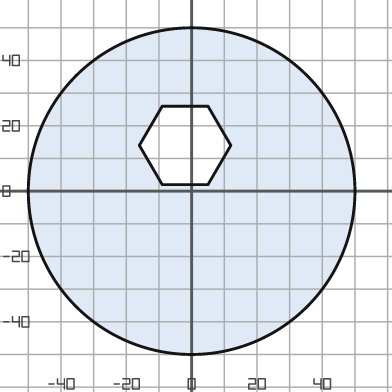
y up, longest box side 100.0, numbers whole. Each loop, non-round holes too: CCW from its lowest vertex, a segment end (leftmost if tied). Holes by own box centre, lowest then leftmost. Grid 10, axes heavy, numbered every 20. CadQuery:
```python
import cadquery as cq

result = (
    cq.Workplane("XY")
    .moveTo(0.0, 0.0)
    .circle(50.0)
    .moveTo(-9.0, 2.0)
    .lineTo(5.0, 2.0)
    .lineTo(12.0, 14.0)
    .lineTo(5.0, 26.0)
    .lineTo(-9.0, 26.0)
    .lineTo(-16.0, 14.0)
    .close()
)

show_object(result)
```